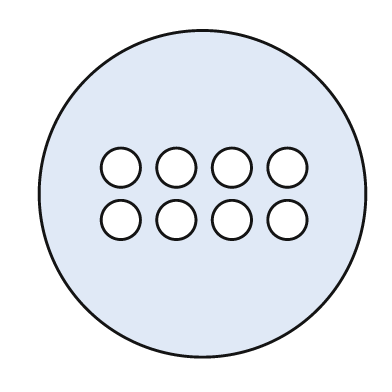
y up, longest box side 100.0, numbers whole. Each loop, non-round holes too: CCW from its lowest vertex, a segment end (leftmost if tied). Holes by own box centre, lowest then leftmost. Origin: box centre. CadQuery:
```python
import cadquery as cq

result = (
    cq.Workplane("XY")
    .moveTo(0.0, 0.0)
    .circle(50.0)
    .moveTo(-25.0, -8.0)
    .circle(6.0)
    .moveTo(-8.0, -8.0)
    .circle(6.0)
    .moveTo(9.0, -8.0)
    .circle(6.0)
    .moveTo(26.0, -8.0)
    .circle(6.0)
    .moveTo(-25.0, 8.0)
    .circle(6.0)
    .moveTo(-8.0, 8.0)
    .circle(6.0)
    .moveTo(9.0, 8.0)
    .circle(6.0)
    .moveTo(26.0, 8.0)
    .circle(6.0)
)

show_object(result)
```